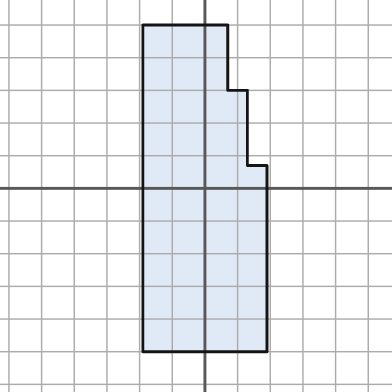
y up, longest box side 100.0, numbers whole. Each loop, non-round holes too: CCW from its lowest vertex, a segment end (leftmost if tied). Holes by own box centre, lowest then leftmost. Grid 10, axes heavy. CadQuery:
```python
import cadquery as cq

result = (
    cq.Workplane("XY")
    .moveTo(-19.0, -50.0)
    .lineTo(19.0, -50.0)
    .lineTo(19.0, 7.0)
    .lineTo(13.0, 7.0)
    .lineTo(13.0, 30.0)
    .lineTo(7.0, 30.0)
    .lineTo(7.0, 50.0)
    .lineTo(-19.0, 50.0)
    .close()
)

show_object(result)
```